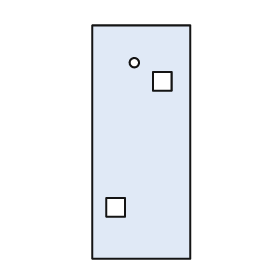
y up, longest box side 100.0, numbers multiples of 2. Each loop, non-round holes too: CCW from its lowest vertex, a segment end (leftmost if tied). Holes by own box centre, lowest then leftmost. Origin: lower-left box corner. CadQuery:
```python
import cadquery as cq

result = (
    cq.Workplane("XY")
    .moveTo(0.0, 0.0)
    .lineTo(42.0, 0.0)
    .lineTo(42.0, 100.0)
    .lineTo(0.0, 100.0)
    .close()
    .moveTo(6.0, 18.0)
    .lineTo(14.0, 18.0)
    .lineTo(14.0, 26.0)
    .lineTo(6.0, 26.0)
    .close()
    .moveTo(26.0, 72.0)
    .lineTo(34.0, 72.0)
    .lineTo(34.0, 80.0)
    .lineTo(26.0, 80.0)
    .close()
    .moveTo(18.0, 84.0)
    .circle(2.0)
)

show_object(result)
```